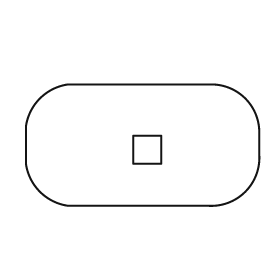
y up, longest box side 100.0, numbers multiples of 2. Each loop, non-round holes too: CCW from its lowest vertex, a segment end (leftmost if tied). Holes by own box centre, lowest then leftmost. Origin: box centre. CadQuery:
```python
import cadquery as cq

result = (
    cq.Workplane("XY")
    .moveTo(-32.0, -26.0)
    .lineTo(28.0, -26.0)
    .threePointArc((44.0, -20.0), (50.0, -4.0))
    .lineTo(50.0, 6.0)
    .threePointArc((44.0, 20.0), (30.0, 26.0))
    .lineTo(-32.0, 26.0)
    .threePointArc((-44.0, 20.0), (-50.0, 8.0))
    .lineTo(-50.0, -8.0)
    .threePointArc((-44.0, -20.0), (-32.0, -26.0))
    .close()
    .moveTo(-4.0, -8.0)
    .lineTo(8.0, -8.0)
    .lineTo(8.0, 4.0)
    .lineTo(-4.0, 4.0)
    .close()
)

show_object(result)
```